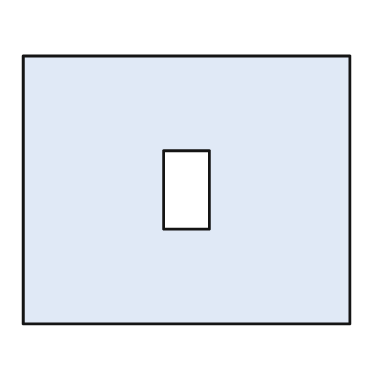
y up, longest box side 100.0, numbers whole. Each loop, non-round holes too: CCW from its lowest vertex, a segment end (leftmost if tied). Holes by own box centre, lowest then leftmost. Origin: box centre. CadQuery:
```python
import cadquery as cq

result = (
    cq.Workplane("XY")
    .moveTo(-50.0, -41.0)
    .lineTo(50.0, -41.0)
    .lineTo(50.0, 41.0)
    .lineTo(-50.0, 41.0)
    .close()
    .moveTo(-7.0, -12.0)
    .lineTo(7.0, -12.0)
    .lineTo(7.0, 12.0)
    .lineTo(-7.0, 12.0)
    .close()
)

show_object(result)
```